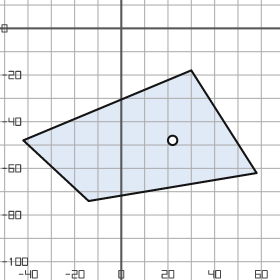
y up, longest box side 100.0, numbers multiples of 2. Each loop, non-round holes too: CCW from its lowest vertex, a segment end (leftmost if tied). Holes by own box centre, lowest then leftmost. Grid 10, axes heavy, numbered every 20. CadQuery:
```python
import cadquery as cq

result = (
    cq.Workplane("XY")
    .moveTo(-14.0, -74.0)
    .lineTo(58.0, -62.0)
    .lineTo(30.0, -18.0)
    .lineTo(-42.0, -48.0)
    .close()
    .moveTo(22.0, -48.0)
    .circle(2.0)
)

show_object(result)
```